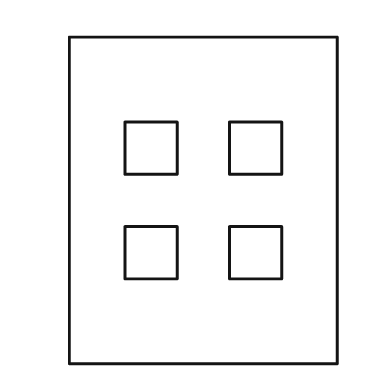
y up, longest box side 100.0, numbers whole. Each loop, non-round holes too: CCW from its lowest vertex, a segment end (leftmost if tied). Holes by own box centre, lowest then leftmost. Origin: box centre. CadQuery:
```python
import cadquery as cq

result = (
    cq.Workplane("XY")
    .moveTo(-41.0, -50.0)
    .lineTo(41.0, -50.0)
    .lineTo(41.0, 50.0)
    .lineTo(-41.0, 50.0)
    .close()
    .moveTo(-24.0, -24.0)
    .lineTo(-8.0, -24.0)
    .lineTo(-8.0, -8.0)
    .lineTo(-24.0, -8.0)
    .close()
    .moveTo(8.0, -24.0)
    .lineTo(24.0, -24.0)
    .lineTo(24.0, -8.0)
    .lineTo(8.0, -8.0)
    .close()
    .moveTo(-24.0, 8.0)
    .lineTo(-8.0, 8.0)
    .lineTo(-8.0, 24.0)
    .lineTo(-24.0, 24.0)
    .close()
    .moveTo(8.0, 8.0)
    .lineTo(24.0, 8.0)
    .lineTo(24.0, 24.0)
    .lineTo(8.0, 24.0)
    .close()
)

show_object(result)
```